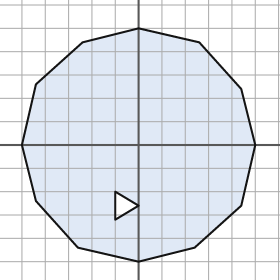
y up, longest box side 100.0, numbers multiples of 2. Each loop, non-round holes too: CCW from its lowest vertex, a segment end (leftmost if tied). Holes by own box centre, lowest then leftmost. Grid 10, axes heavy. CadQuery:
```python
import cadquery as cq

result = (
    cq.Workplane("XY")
    .moveTo(0.0, -50.0)
    .lineTo(24.0, -44.0)
    .lineTo(44.0, -26.0)
    .lineTo(50.0, 0.0)
    .lineTo(44.0, 24.0)
    .lineTo(26.0, 44.0)
    .lineTo(0.0, 50.0)
    .lineTo(-24.0, 44.0)
    .lineTo(-44.0, 26.0)
    .lineTo(-50.0, 0.0)
    .lineTo(-44.0, -24.0)
    .lineTo(-26.0, -44.0)
    .close()
    .moveTo(-10.0, -32.0)
    .lineTo(0.0, -26.0)
    .lineTo(-10.0, -20.0)
    .close()
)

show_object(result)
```